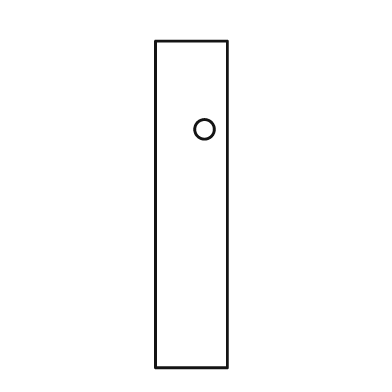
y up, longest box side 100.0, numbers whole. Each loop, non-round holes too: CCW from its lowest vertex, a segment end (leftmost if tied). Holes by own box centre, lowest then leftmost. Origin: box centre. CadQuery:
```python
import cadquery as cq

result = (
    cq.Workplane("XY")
    .moveTo(-11.0, -50.0)
    .lineTo(11.0, -50.0)
    .lineTo(11.0, 50.0)
    .lineTo(-11.0, 50.0)
    .close()
    .moveTo(4.0, 23.0)
    .circle(3.0)
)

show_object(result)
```